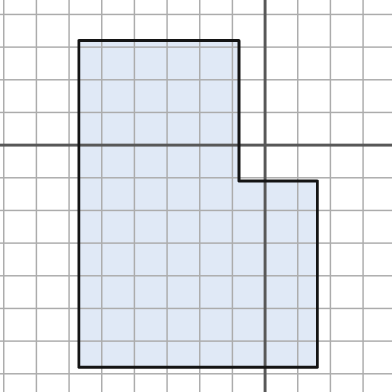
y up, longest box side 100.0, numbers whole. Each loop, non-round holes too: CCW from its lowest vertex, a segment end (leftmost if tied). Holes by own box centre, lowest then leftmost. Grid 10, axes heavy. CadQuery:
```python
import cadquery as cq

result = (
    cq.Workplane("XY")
    .moveTo(-57.0, -68.0)
    .lineTo(16.0, -68.0)
    .lineTo(16.0, -11.0)
    .lineTo(-8.0, -11.0)
    .lineTo(-8.0, 32.0)
    .lineTo(-57.0, 32.0)
    .close()
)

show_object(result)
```